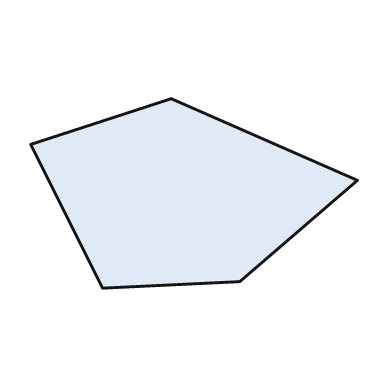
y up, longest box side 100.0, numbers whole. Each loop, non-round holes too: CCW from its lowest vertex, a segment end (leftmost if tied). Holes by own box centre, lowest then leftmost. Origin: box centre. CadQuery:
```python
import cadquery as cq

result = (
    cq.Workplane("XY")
    .moveTo(-28.0, -29.0)
    .lineTo(14.0, -27.0)
    .lineTo(50.0, 4.0)
    .lineTo(-7.0, 29.0)
    .lineTo(-50.0, 15.0)
    .close()
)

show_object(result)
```